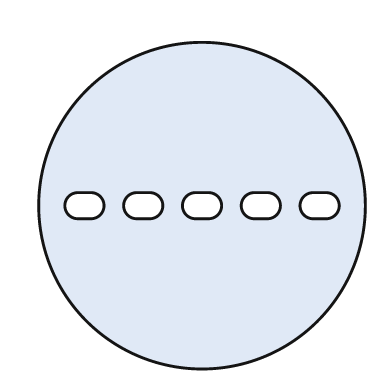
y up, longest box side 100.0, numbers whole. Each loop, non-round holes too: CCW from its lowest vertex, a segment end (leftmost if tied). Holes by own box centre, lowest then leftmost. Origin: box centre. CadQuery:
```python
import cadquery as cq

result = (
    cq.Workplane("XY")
    .moveTo(0.0, 0.0)
    .circle(50.0)
    .moveTo(-38.0, -4.0)
    .lineTo(-34.0, -4.0)
    .threePointArc((-30.0, 0.0), (-34.0, 4.0))
    .lineTo(-38.0, 4.0)
    .threePointArc((-42.0, 0.0), (-38.0, -4.0))
    .close()
    .moveTo(-20.0, -4.0)
    .lineTo(-16.0, -4.0)
    .threePointArc((-12.0, 0.0), (-16.0, 4.0))
    .lineTo(-20.0, 4.0)
    .threePointArc((-24.0, 0.0), (-20.0, -4.0))
    .close()
    .moveTo(-2.0, -4.0)
    .lineTo(2.0, -4.0)
    .threePointArc((6.0, 0.0), (2.0, 4.0))
    .lineTo(-2.0, 4.0)
    .threePointArc((-6.0, 0.0), (-2.0, -4.0))
    .close()
    .moveTo(16.0, -4.0)
    .lineTo(20.0, -4.0)
    .threePointArc((24.0, 0.0), (20.0, 4.0))
    .lineTo(16.0, 4.0)
    .threePointArc((12.0, 0.0), (16.0, -4.0))
    .close()
    .moveTo(34.0, -4.0)
    .lineTo(38.0, -4.0)
    .threePointArc((42.0, 0.0), (38.0, 4.0))
    .lineTo(34.0, 4.0)
    .threePointArc((30.0, 0.0), (34.0, -4.0))
    .close()
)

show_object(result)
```